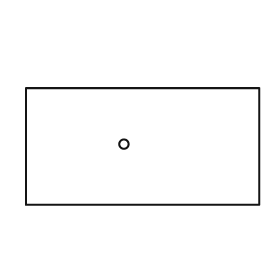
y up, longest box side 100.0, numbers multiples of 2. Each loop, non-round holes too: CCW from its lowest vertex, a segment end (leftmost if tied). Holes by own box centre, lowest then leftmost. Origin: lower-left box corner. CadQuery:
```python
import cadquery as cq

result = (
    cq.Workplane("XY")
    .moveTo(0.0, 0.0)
    .lineTo(100.0, 0.0)
    .lineTo(100.0, 50.0)
    .lineTo(0.0, 50.0)
    .close()
    .moveTo(42.0, 26.0)
    .circle(2.0)
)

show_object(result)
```